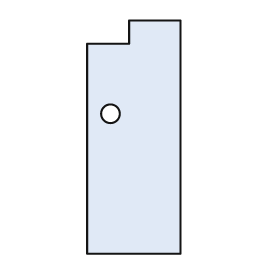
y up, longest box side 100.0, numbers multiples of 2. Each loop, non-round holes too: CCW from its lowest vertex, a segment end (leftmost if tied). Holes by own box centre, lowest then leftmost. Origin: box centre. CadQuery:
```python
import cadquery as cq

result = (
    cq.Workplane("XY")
    .moveTo(-20.0, -50.0)
    .lineTo(20.0, -50.0)
    .lineTo(20.0, 50.0)
    .lineTo(-2.0, 50.0)
    .lineTo(-2.0, 40.0)
    .lineTo(-20.0, 40.0)
    .close()
    .moveTo(-10.0, 10.0)
    .circle(4.0)
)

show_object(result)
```